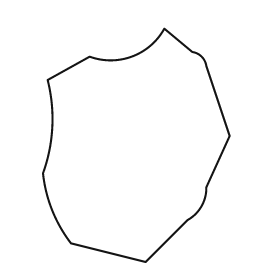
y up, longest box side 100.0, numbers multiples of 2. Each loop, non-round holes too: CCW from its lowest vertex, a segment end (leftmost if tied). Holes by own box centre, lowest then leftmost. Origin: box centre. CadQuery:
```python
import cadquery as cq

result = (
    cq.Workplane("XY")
    .moveTo(4.0, -50.0)
    .lineTo(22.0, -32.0)
    .threePointArc((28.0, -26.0), (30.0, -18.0))
    .lineTo(40.0, 4.0)
    .lineTo(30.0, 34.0)
    .threePointArc((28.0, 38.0), (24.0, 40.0))
    .lineTo(12.0, 50.0)
    .threePointArc((-2.0, 38.0), (-20.0, 38.0))
    .lineTo(-38.0, 28.0)
    .threePointArc((-36.0, 8.0), (-40.0, -12.0))
    .threePointArc((-36.0, -28.0), (-28.0, -42.0))
    .close()
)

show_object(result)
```